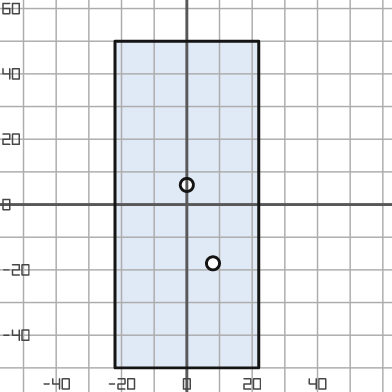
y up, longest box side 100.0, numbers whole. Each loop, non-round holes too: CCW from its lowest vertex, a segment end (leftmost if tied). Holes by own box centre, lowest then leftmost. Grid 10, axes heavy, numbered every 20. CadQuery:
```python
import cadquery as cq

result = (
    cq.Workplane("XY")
    .moveTo(-22.0, -50.0)
    .lineTo(22.0, -50.0)
    .lineTo(22.0, 50.0)
    .lineTo(-22.0, 50.0)
    .close()
    .moveTo(8.0, -18.0)
    .circle(2.0)
    .moveTo(0.0, 6.0)
    .circle(2.0)
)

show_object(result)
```